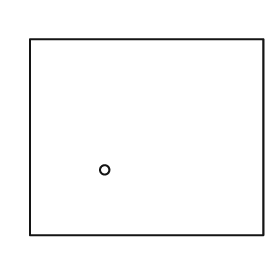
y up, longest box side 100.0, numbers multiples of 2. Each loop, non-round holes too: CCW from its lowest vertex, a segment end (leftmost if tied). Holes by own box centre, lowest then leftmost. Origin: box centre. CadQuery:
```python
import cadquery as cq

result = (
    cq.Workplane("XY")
    .moveTo(-50.0, -42.0)
    .lineTo(50.0, -42.0)
    .lineTo(50.0, 42.0)
    .lineTo(-50.0, 42.0)
    .close()
    .moveTo(-18.0, -14.0)
    .circle(2.0)
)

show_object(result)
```